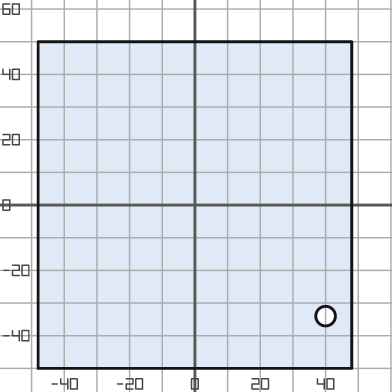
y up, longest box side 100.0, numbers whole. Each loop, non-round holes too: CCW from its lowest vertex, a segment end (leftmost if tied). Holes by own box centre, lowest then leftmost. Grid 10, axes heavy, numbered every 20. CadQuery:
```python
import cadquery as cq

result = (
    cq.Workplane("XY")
    .moveTo(-48.0, -50.0)
    .lineTo(48.0, -50.0)
    .lineTo(48.0, 50.0)
    .lineTo(-48.0, 50.0)
    .close()
    .moveTo(40.0, -34.0)
    .circle(3.0)
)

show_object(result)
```